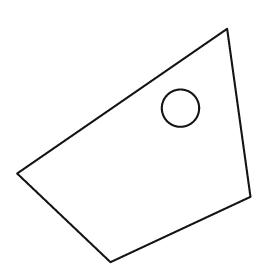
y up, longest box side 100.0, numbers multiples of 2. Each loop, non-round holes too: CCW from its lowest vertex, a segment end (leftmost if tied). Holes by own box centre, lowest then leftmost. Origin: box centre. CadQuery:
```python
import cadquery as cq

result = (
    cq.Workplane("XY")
    .moveTo(-10.0, -50.0)
    .lineTo(50.0, -22.0)
    .lineTo(40.0, 50.0)
    .lineTo(-50.0, -12.0)
    .close()
    .moveTo(20.0, 16.0)
    .circle(8.0)
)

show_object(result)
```